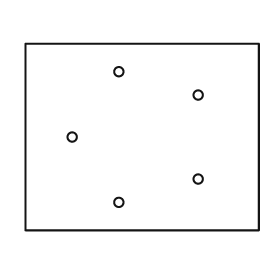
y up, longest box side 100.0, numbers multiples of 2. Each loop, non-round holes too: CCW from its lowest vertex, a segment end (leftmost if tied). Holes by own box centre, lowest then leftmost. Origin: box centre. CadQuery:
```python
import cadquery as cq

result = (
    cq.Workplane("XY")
    .moveTo(-50.0, -40.0)
    .lineTo(50.0, -40.0)
    .lineTo(50.0, 40.0)
    .lineTo(-50.0, 40.0)
    .close()
    .moveTo(-10.0, -28.0)
    .circle(2.0)
    .moveTo(24.0, -18.0)
    .circle(2.0)
    .moveTo(-30.0, 0.0)
    .circle(2.0)
    .moveTo(24.0, 18.0)
    .circle(2.0)
    .moveTo(-10.0, 28.0)
    .circle(2.0)
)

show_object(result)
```